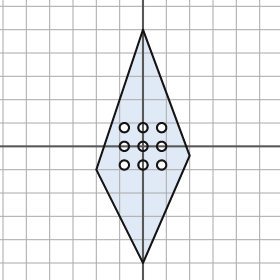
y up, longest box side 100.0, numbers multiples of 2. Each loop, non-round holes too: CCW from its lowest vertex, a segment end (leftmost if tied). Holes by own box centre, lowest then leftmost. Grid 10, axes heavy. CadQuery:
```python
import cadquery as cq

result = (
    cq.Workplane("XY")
    .moveTo(0.0, -50.0)
    .lineTo(20.0, -4.0)
    .lineTo(0.0, 50.0)
    .lineTo(-20.0, -10.0)
    .close()
    .moveTo(-8.0, -8.0)
    .circle(2.0)
    .moveTo(0.0, -8.0)
    .circle(2.0)
    .moveTo(8.0, -8.0)
    .circle(2.0)
    .moveTo(-8.0, 0.0)
    .circle(2.0)
    .moveTo(0.0, 0.0)
    .circle(2.0)
    .moveTo(8.0, 0.0)
    .circle(2.0)
    .moveTo(-8.0, 8.0)
    .circle(2.0)
    .moveTo(0.0, 8.0)
    .circle(2.0)
    .moveTo(8.0, 8.0)
    .circle(2.0)
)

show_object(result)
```